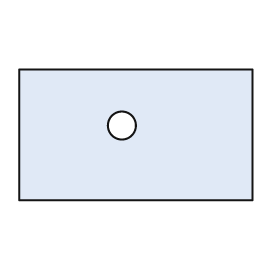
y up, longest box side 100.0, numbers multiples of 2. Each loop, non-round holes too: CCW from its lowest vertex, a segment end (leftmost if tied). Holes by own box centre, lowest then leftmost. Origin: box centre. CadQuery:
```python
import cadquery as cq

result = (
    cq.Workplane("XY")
    .moveTo(-50.0, -28.0)
    .lineTo(50.0, -28.0)
    .lineTo(50.0, 28.0)
    .lineTo(-50.0, 28.0)
    .close()
    .moveTo(-6.0, 4.0)
    .circle(6.0)
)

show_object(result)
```